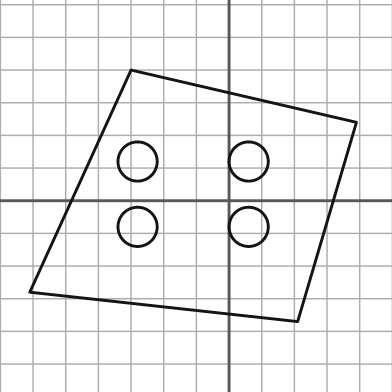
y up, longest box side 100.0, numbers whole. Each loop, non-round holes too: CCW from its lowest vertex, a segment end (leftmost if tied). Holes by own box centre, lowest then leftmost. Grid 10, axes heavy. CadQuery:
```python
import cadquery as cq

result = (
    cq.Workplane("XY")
    .moveTo(21.0, -37.0)
    .lineTo(39.0, 24.0)
    .lineTo(-30.0, 40.0)
    .lineTo(-61.0, -28.0)
    .close()
    .moveTo(-28.0, -8.0)
    .circle(6.0)
    .moveTo(6.0, -8.0)
    .circle(6.0)
    .moveTo(-28.0, 12.0)
    .circle(6.0)
    .moveTo(6.0, 12.0)
    .circle(6.0)
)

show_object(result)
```